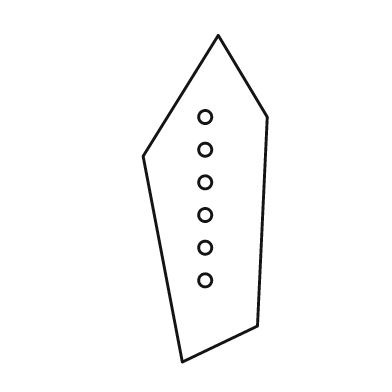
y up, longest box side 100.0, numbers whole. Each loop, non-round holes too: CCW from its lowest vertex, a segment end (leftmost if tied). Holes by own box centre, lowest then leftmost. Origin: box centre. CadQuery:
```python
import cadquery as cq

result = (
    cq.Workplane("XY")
    .moveTo(-7.0, -50.0)
    .lineTo(16.0, -39.0)
    .lineTo(19.0, 25.0)
    .lineTo(4.0, 50.0)
    .lineTo(-19.0, 13.0)
    .close()
    .moveTo(0.0, -25.0)
    .circle(2.0)
    .moveTo(0.0, -15.0)
    .circle(2.0)
    .moveTo(0.0, -5.0)
    .circle(2.0)
    .moveTo(0.0, 5.0)
    .circle(2.0)
    .moveTo(0.0, 15.0)
    .circle(2.0)
    .moveTo(0.0, 25.0)
    .circle(2.0)
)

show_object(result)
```